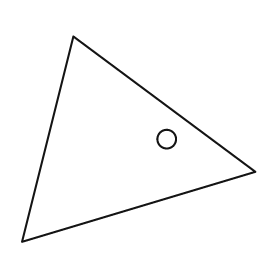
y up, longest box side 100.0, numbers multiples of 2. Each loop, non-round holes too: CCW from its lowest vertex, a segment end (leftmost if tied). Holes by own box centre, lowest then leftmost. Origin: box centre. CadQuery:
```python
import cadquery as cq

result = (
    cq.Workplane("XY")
    .moveTo(-50.0, -44.0)
    .lineTo(50.0, -14.0)
    .lineTo(-28.0, 44.0)
    .close()
    .moveTo(12.0, 0.0)
    .circle(4.0)
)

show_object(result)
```